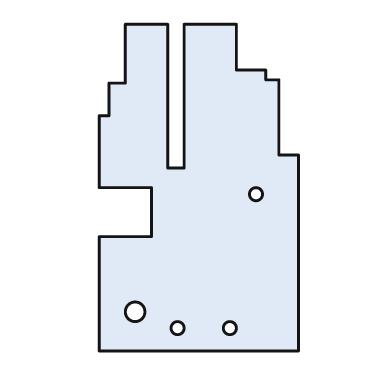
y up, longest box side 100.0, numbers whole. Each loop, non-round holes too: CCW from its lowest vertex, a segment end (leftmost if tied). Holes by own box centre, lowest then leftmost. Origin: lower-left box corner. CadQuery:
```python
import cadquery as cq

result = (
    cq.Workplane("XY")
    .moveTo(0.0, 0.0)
    .lineTo(61.0, 0.0)
    .lineTo(61.0, 60.0)
    .lineTo(55.0, 60.0)
    .lineTo(55.0, 83.0)
    .lineTo(51.0, 83.0)
    .lineTo(51.0, 86.0)
    .lineTo(42.0, 86.0)
    .lineTo(42.0, 100.0)
    .lineTo(26.0, 100.0)
    .lineTo(26.0, 56.0)
    .lineTo(21.0, 56.0)
    .lineTo(21.0, 100.0)
    .lineTo(8.0, 100.0)
    .lineTo(8.0, 82.0)
    .lineTo(3.0, 82.0)
    .lineTo(3.0, 72.0)
    .lineTo(0.0, 72.0)
    .lineTo(0.0, 50.0)
    .lineTo(16.0, 50.0)
    .lineTo(16.0, 35.0)
    .lineTo(0.0, 35.0)
    .close()
    .moveTo(24.0, 7.0)
    .circle(2.0)
    .moveTo(40.0, 7.0)
    .circle(2.0)
    .moveTo(11.0, 12.0)
    .circle(3.0)
    .moveTo(48.0, 48.0)
    .circle(2.0)
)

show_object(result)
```